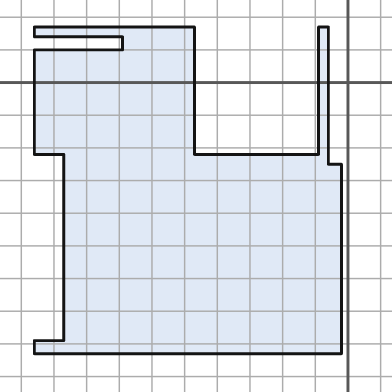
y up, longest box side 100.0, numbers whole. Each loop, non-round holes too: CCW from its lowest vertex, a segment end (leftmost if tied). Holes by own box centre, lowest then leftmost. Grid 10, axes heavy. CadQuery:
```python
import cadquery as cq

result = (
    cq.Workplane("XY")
    .moveTo(-96.0, -83.0)
    .lineTo(-2.0, -83.0)
    .lineTo(-2.0, -25.0)
    .lineTo(-6.0, -25.0)
    .lineTo(-6.0, 17.0)
    .lineTo(-9.0, 17.0)
    .lineTo(-9.0, -22.0)
    .lineTo(-47.0, -22.0)
    .lineTo(-47.0, 17.0)
    .lineTo(-96.0, 17.0)
    .lineTo(-96.0, 14.0)
    .lineTo(-69.0, 14.0)
    .lineTo(-69.0, 10.0)
    .lineTo(-96.0, 10.0)
    .lineTo(-96.0, -22.0)
    .lineTo(-87.0, -22.0)
    .lineTo(-87.0, -79.0)
    .lineTo(-96.0, -79.0)
    .close()
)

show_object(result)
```